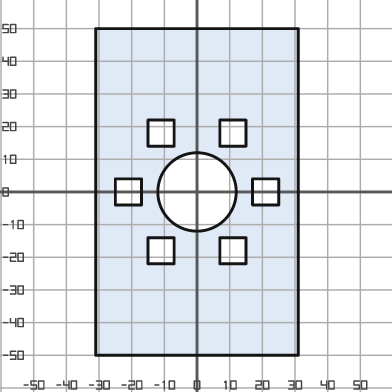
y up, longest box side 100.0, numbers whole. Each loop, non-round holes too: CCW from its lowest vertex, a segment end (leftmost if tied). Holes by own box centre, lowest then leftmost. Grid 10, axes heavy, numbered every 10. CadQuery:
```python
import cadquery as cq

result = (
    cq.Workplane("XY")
    .moveTo(-31.0, -50.0)
    .lineTo(31.0, -50.0)
    .lineTo(31.0, 50.0)
    .lineTo(-31.0, 50.0)
    .close()
    .moveTo(-15.0, -22.0)
    .lineTo(-7.0, -22.0)
    .lineTo(-7.0, -14.0)
    .lineTo(-15.0, -14.0)
    .close()
    .moveTo(7.0, -22.0)
    .lineTo(15.0, -22.0)
    .lineTo(15.0, -14.0)
    .lineTo(7.0, -14.0)
    .close()
    .moveTo(-25.0, -4.0)
    .lineTo(-17.0, -4.0)
    .lineTo(-17.0, 4.0)
    .lineTo(-25.0, 4.0)
    .close()
    .moveTo(0.0, 0.0)
    .circle(12.0)
    .moveTo(17.0, -4.0)
    .lineTo(25.0, -4.0)
    .lineTo(25.0, 4.0)
    .lineTo(17.0, 4.0)
    .close()
    .moveTo(-15.0, 14.0)
    .lineTo(-7.0, 14.0)
    .lineTo(-7.0, 22.0)
    .lineTo(-15.0, 22.0)
    .close()
    .moveTo(7.0, 14.0)
    .lineTo(15.0, 14.0)
    .lineTo(15.0, 22.0)
    .lineTo(7.0, 22.0)
    .close()
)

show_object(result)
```